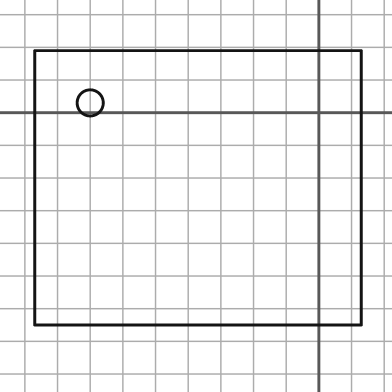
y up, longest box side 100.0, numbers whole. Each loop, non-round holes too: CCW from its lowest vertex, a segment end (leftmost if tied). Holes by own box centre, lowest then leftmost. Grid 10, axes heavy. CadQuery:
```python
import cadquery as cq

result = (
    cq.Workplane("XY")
    .moveTo(-87.0, -65.0)
    .lineTo(13.0, -65.0)
    .lineTo(13.0, 19.0)
    .lineTo(-87.0, 19.0)
    .close()
    .moveTo(-70.0, 3.0)
    .circle(4.0)
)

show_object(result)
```